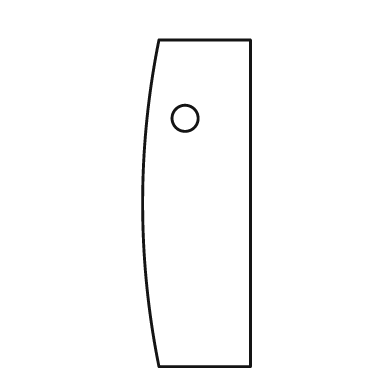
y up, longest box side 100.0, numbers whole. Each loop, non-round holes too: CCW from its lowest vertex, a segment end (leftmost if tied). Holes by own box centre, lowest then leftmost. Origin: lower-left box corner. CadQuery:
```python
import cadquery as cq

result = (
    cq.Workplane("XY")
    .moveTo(5.0, 0.0)
    .lineTo(33.0, 0.0)
    .lineTo(33.0, 100.0)
    .lineTo(5.0, 100.0)
    .threePointArc((0.0, 50.0), (5.0, 0.0))
    .close()
    .moveTo(13.0, 76.0)
    .circle(4.0)
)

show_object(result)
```